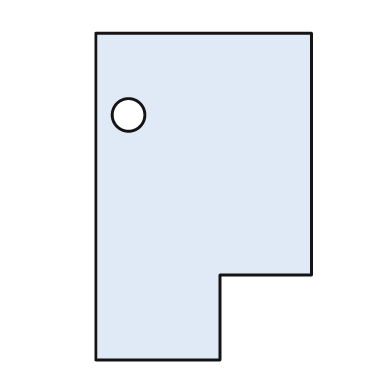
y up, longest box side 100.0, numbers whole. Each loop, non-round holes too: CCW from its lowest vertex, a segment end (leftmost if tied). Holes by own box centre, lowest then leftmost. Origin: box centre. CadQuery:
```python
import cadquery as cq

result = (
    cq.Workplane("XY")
    .moveTo(-33.0, -50.0)
    .lineTo(5.0, -50.0)
    .lineTo(5.0, -24.0)
    .lineTo(33.0, -24.0)
    .lineTo(33.0, 50.0)
    .lineTo(-33.0, 50.0)
    .close()
    .moveTo(-23.0, 25.0)
    .circle(5.0)
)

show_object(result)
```